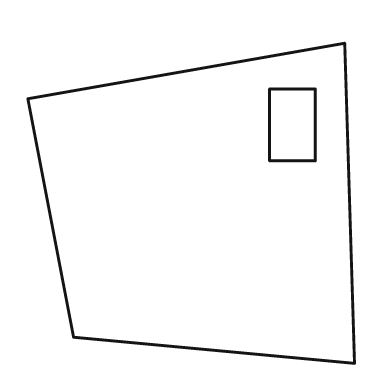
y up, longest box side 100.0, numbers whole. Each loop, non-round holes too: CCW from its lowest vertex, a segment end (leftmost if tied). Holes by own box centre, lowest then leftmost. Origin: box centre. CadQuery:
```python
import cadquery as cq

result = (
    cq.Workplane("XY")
    .moveTo(50.0, -49.0)
    .lineTo(47.0, 49.0)
    .lineTo(-50.0, 32.0)
    .lineTo(-36.0, -41.0)
    .close()
    .moveTo(24.0, 13.0)
    .lineTo(38.0, 13.0)
    .lineTo(38.0, 35.0)
    .lineTo(24.0, 35.0)
    .close()
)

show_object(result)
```